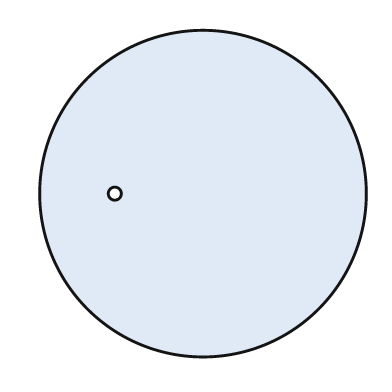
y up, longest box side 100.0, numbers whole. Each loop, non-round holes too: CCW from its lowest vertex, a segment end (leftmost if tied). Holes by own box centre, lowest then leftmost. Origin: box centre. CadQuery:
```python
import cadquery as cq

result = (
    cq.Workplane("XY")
    .moveTo(0.0, 0.0)
    .circle(50.0)
    .moveTo(-27.0, 0.0)
    .circle(2.0)
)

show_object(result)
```